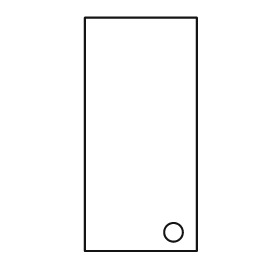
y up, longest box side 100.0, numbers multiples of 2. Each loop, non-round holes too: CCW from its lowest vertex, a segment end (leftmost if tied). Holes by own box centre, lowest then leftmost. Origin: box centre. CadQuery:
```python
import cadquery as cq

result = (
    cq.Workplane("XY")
    .moveTo(-24.0, -50.0)
    .lineTo(24.0, -50.0)
    .lineTo(24.0, 50.0)
    .lineTo(-24.0, 50.0)
    .close()
    .moveTo(14.0, -42.0)
    .circle(4.0)
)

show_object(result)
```